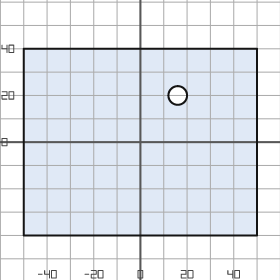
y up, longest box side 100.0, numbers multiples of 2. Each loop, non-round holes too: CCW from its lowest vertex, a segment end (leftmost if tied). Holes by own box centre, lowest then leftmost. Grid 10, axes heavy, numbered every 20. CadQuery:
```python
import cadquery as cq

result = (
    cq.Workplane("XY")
    .moveTo(-50.0, -40.0)
    .lineTo(50.0, -40.0)
    .lineTo(50.0, 40.0)
    .lineTo(-50.0, 40.0)
    .close()
    .moveTo(16.0, 20.0)
    .circle(4.0)
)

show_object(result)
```